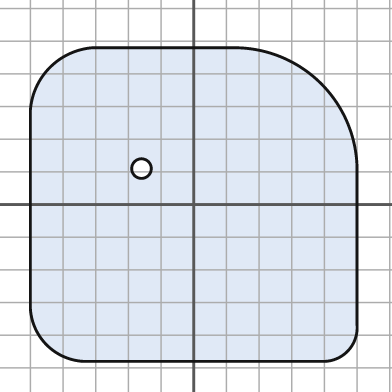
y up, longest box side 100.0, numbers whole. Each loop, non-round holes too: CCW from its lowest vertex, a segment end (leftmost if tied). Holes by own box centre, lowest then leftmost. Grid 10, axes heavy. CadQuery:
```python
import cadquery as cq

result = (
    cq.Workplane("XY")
    .moveTo(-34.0, -48.0)
    .lineTo(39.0, -48.0)
    .threePointArc((47.0, -45.0), (50.0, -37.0))
    .lineTo(50.0, 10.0)
    .threePointArc((39.0, 37.0), (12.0, 48.0))
    .lineTo(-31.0, 48.0)
    .threePointArc((-44.0, 42.0), (-50.0, 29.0))
    .lineTo(-50.0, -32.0)
    .threePointArc((-45.0, -43.0), (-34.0, -48.0))
    .close()
    .moveTo(-16.0, 11.0)
    .circle(3.0)
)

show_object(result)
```